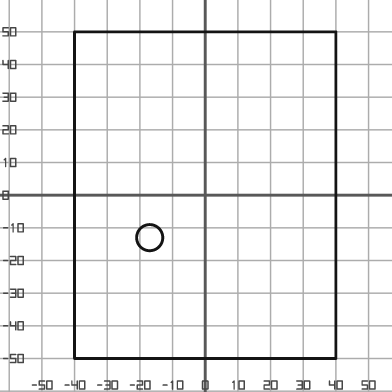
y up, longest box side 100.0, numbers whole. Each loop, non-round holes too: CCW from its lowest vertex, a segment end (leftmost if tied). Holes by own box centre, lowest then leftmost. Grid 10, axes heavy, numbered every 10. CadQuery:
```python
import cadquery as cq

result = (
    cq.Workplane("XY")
    .moveTo(-40.0, -50.0)
    .lineTo(40.0, -50.0)
    .lineTo(40.0, 50.0)
    .lineTo(-40.0, 50.0)
    .close()
    .moveTo(-17.0, -13.0)
    .circle(4.0)
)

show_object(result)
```